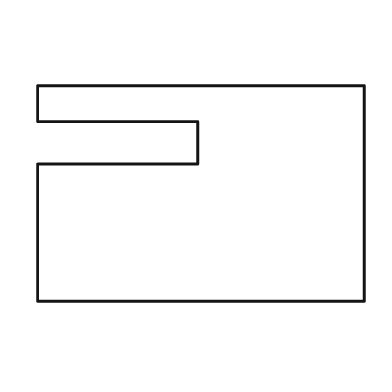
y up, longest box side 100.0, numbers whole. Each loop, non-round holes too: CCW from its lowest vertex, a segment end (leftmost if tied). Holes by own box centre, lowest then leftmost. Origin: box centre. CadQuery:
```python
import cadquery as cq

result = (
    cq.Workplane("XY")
    .moveTo(-50.0, -33.0)
    .lineTo(50.0, -33.0)
    .lineTo(50.0, 33.0)
    .lineTo(-50.0, 33.0)
    .lineTo(-50.0, 22.0)
    .lineTo(-1.0, 22.0)
    .lineTo(-1.0, 9.0)
    .lineTo(-50.0, 9.0)
    .close()
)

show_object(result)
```